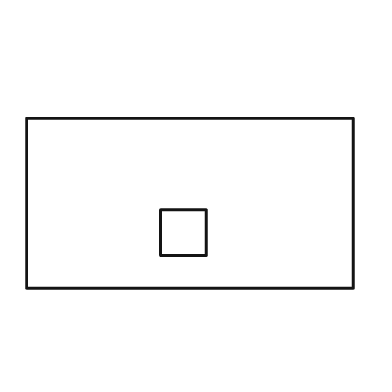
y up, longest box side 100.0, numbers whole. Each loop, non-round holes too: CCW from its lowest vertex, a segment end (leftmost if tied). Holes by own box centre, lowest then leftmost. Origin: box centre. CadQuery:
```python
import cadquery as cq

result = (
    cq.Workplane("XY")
    .moveTo(-50.0, -26.0)
    .lineTo(50.0, -26.0)
    .lineTo(50.0, 26.0)
    .lineTo(-50.0, 26.0)
    .close()
    .moveTo(-9.0, -16.0)
    .lineTo(5.0, -16.0)
    .lineTo(5.0, -2.0)
    .lineTo(-9.0, -2.0)
    .close()
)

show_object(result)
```